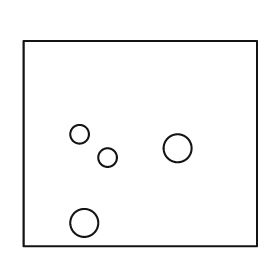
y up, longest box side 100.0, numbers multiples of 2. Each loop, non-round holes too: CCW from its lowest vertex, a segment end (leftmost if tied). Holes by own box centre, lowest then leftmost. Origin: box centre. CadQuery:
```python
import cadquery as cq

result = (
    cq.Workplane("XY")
    .moveTo(-50.0, -44.0)
    .lineTo(50.0, -44.0)
    .lineTo(50.0, 44.0)
    .lineTo(-50.0, 44.0)
    .close()
    .moveTo(-24.0, -34.0)
    .circle(6.0)
    .moveTo(-14.0, -6.0)
    .circle(4.0)
    .moveTo(16.0, -2.0)
    .circle(6.0)
    .moveTo(-26.0, 4.0)
    .circle(4.0)
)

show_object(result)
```